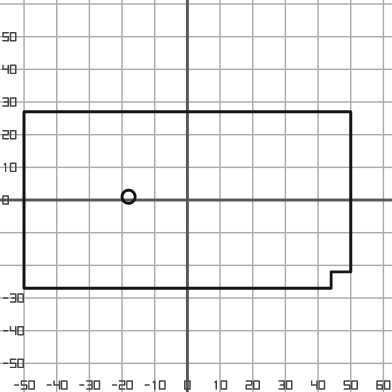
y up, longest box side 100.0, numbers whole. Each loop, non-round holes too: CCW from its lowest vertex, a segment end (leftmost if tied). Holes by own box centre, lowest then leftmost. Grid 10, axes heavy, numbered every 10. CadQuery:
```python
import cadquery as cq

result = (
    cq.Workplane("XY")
    .moveTo(-50.0, -27.0)
    .lineTo(44.0, -27.0)
    .lineTo(44.0, -22.0)
    .lineTo(50.0, -22.0)
    .lineTo(50.0, 27.0)
    .lineTo(-50.0, 27.0)
    .close()
    .moveTo(-18.0, 1.0)
    .circle(2.0)
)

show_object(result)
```